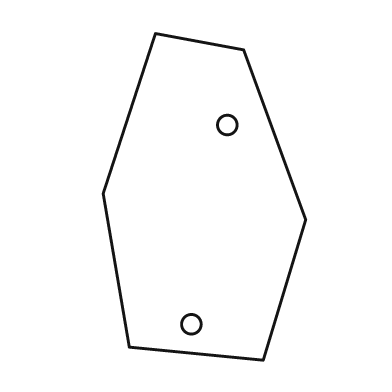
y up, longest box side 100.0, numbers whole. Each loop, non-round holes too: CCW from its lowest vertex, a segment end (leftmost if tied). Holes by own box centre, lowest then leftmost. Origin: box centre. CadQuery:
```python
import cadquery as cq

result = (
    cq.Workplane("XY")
    .moveTo(18.0, -50.0)
    .lineTo(31.0, -7.0)
    .lineTo(12.0, 45.0)
    .lineTo(-15.0, 50.0)
    .lineTo(-31.0, 1.0)
    .lineTo(-23.0, -46.0)
    .close()
    .moveTo(-4.0, -39.0)
    .circle(3.0)
    .moveTo(7.0, 22.0)
    .circle(3.0)
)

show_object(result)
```